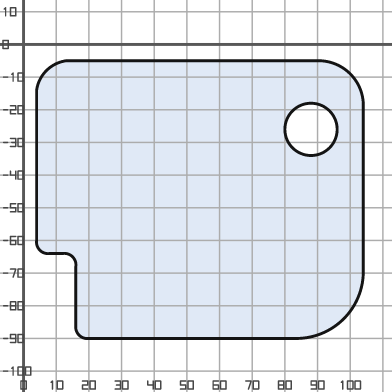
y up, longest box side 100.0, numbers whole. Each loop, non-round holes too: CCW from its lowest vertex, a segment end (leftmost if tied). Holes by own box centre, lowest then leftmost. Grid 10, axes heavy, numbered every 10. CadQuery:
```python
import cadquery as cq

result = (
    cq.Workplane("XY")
    .moveTo(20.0, -90.0)
    .lineTo(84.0, -90.0)
    .threePointArc((98.0, -84.0), (104.0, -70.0))
    .lineTo(104.0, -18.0)
    .threePointArc((100.0, -9.0), (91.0, -5.0))
    .lineTo(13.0, -5.0)
    .threePointArc((7.0, -8.0), (4.0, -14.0))
    .lineTo(4.0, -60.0)
    .threePointArc((5.0, -63.0), (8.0, -64.0))
    .lineTo(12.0, -64.0)
    .threePointArc((15.0, -65.0), (16.0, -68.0))
    .lineTo(16.0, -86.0)
    .threePointArc((17.0, -89.0), (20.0, -90.0))
    .close()
    .moveTo(88.0, -26.0)
    .circle(8.0)
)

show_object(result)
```